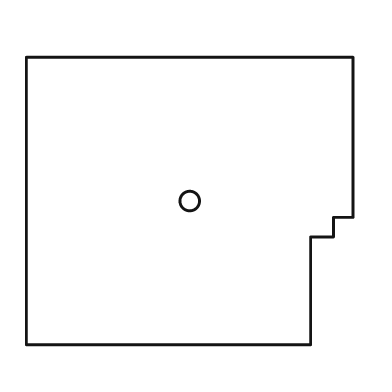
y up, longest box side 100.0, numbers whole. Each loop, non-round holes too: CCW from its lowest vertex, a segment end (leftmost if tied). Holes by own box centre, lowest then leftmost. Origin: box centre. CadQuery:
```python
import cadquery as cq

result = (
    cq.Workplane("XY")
    .moveTo(-50.0, -44.0)
    .lineTo(37.0, -44.0)
    .lineTo(37.0, -11.0)
    .lineTo(44.0, -11.0)
    .lineTo(44.0, -5.0)
    .lineTo(50.0, -5.0)
    .lineTo(50.0, 44.0)
    .lineTo(-50.0, 44.0)
    .close()
    .moveTo(0.0, 0.0)
    .circle(3.0)
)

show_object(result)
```